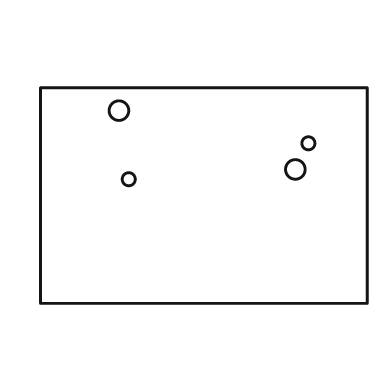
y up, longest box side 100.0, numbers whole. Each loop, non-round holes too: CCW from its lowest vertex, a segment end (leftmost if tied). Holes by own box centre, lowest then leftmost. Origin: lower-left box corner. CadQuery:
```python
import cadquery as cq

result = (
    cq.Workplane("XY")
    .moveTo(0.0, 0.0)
    .lineTo(100.0, 0.0)
    .lineTo(100.0, 66.0)
    .lineTo(0.0, 66.0)
    .close()
    .moveTo(27.0, 38.0)
    .circle(2.0)
    .moveTo(78.0, 41.0)
    .circle(3.0)
    .moveTo(82.0, 49.0)
    .circle(2.0)
    .moveTo(24.0, 59.0)
    .circle(3.0)
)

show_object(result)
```